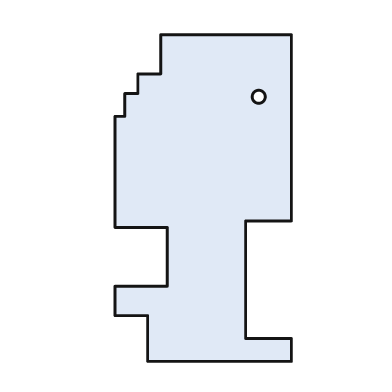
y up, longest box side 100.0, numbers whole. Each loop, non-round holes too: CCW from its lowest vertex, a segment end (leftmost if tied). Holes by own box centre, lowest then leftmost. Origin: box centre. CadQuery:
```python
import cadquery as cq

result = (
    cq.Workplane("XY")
    .moveTo(-17.0, -50.0)
    .lineTo(27.0, -50.0)
    .lineTo(27.0, -43.0)
    .lineTo(13.0, -43.0)
    .lineTo(13.0, -7.0)
    .lineTo(27.0, -7.0)
    .lineTo(27.0, 50.0)
    .lineTo(-13.0, 50.0)
    .lineTo(-13.0, 38.0)
    .lineTo(-20.0, 38.0)
    .lineTo(-20.0, 32.0)
    .lineTo(-24.0, 32.0)
    .lineTo(-24.0, 25.0)
    .lineTo(-27.0, 25.0)
    .lineTo(-27.0, -9.0)
    .lineTo(-11.0, -9.0)
    .lineTo(-11.0, -27.0)
    .lineTo(-27.0, -27.0)
    .lineTo(-27.0, -36.0)
    .lineTo(-17.0, -36.0)
    .close()
    .moveTo(17.0, 31.0)
    .circle(2.0)
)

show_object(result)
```